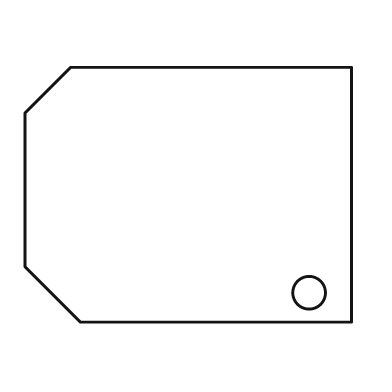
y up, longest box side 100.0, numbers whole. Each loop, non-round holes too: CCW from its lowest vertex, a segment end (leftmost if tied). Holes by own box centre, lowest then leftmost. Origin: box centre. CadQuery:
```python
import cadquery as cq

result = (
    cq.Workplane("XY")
    .moveTo(-33.0, -39.0)
    .lineTo(50.0, -39.0)
    .lineTo(50.0, 39.0)
    .lineTo(-36.0, 39.0)
    .lineTo(-50.0, 25.0)
    .lineTo(-50.0, -22.0)
    .close()
    .moveTo(37.0, -30.0)
    .circle(5.0)
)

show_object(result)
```